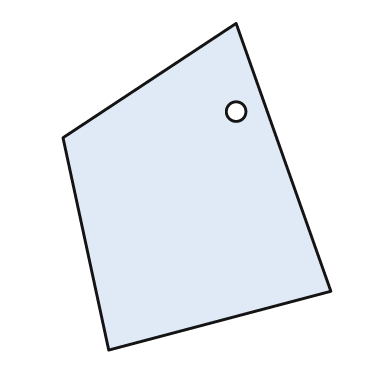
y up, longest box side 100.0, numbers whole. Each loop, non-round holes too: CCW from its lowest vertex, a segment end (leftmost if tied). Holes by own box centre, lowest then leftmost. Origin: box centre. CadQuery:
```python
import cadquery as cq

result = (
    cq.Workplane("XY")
    .moveTo(-27.0, -50.0)
    .lineTo(41.0, -32.0)
    .lineTo(12.0, 50.0)
    .lineTo(-41.0, 15.0)
    .close()
    .moveTo(12.0, 23.0)
    .circle(3.0)
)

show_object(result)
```